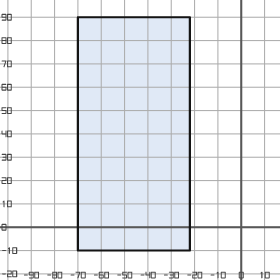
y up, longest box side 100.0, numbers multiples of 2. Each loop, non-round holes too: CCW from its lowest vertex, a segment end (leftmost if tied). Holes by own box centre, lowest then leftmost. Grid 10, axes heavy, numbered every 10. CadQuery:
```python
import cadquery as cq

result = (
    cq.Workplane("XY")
    .moveTo(-70.0, -10.0)
    .lineTo(-22.0, -10.0)
    .lineTo(-22.0, 90.0)
    .lineTo(-70.0, 90.0)
    .close()
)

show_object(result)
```